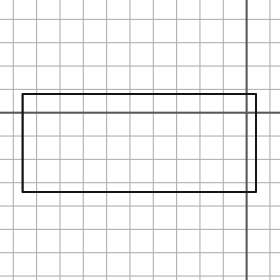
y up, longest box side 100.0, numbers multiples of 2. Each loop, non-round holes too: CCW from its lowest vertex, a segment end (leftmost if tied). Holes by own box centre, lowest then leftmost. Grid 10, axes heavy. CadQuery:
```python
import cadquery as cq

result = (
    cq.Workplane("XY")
    .moveTo(-96.0, -34.0)
    .lineTo(4.0, -34.0)
    .lineTo(4.0, 8.0)
    .lineTo(-96.0, 8.0)
    .close()
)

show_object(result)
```